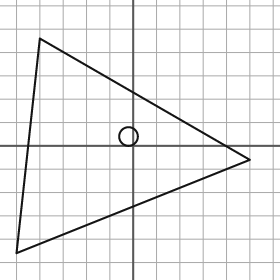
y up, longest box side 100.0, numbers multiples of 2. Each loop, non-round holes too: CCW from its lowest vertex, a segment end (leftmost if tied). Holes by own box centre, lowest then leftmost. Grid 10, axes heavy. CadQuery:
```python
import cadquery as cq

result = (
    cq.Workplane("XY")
    .moveTo(-50.0, -46.0)
    .lineTo(50.0, -6.0)
    .lineTo(-40.0, 46.0)
    .close()
    .moveTo(-2.0, 4.0)
    .circle(4.0)
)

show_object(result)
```